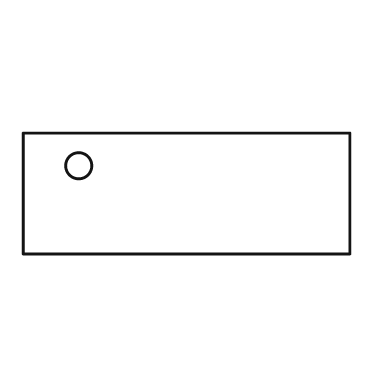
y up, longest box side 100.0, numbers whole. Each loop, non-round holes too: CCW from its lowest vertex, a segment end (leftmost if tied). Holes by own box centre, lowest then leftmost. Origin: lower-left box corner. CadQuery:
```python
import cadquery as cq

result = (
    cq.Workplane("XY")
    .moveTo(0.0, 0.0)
    .lineTo(100.0, 0.0)
    .lineTo(100.0, 37.0)
    .lineTo(0.0, 37.0)
    .close()
    .moveTo(17.0, 27.0)
    .circle(4.0)
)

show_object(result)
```